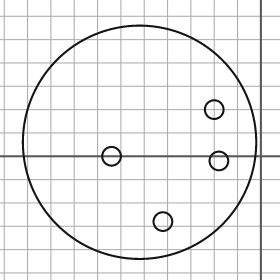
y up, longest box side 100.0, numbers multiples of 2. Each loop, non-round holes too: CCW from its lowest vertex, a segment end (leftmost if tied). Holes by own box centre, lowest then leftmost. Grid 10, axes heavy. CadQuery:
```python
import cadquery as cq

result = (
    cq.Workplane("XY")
    .moveTo(-52.0, 6.0)
    .circle(50.0)
    .moveTo(-42.0, -28.0)
    .circle(4.0)
    .moveTo(-18.0, -2.0)
    .circle(4.0)
    .moveTo(-64.0, 0.0)
    .circle(4.0)
    .moveTo(-20.0, 20.0)
    .circle(4.0)
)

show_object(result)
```